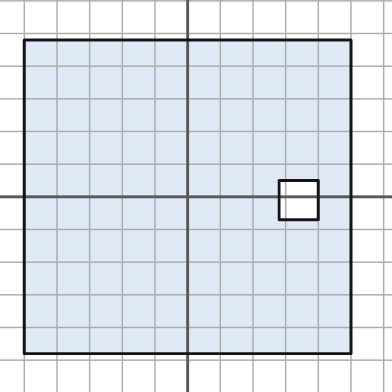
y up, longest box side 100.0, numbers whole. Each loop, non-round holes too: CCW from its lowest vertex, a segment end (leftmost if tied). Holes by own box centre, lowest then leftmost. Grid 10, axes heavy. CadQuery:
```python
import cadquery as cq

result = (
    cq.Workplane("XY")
    .moveTo(-50.0, -48.0)
    .lineTo(50.0, -48.0)
    .lineTo(50.0, 48.0)
    .lineTo(-50.0, 48.0)
    .close()
    .moveTo(28.0, -7.0)
    .lineTo(40.0, -7.0)
    .lineTo(40.0, 5.0)
    .lineTo(28.0, 5.0)
    .close()
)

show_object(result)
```